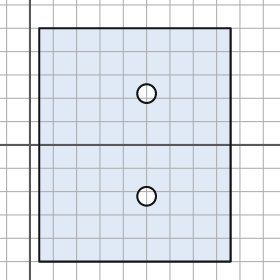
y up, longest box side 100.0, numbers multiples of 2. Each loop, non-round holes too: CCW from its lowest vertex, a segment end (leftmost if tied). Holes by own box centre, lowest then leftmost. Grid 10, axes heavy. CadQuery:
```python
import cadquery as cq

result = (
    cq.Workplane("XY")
    .moveTo(4.0, -50.0)
    .lineTo(86.0, -50.0)
    .lineTo(86.0, 50.0)
    .lineTo(4.0, 50.0)
    .close()
    .moveTo(50.0, -22.0)
    .circle(4.0)
    .moveTo(50.0, 22.0)
    .circle(4.0)
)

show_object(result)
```